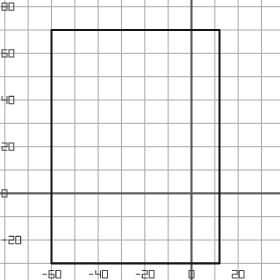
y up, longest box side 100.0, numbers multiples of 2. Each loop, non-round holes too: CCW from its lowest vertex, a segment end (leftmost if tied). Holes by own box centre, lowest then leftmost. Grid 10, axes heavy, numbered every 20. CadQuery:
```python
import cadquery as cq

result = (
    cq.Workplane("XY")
    .moveTo(-60.0, -30.0)
    .lineTo(12.0, -30.0)
    .lineTo(12.0, 70.0)
    .lineTo(-60.0, 70.0)
    .close()
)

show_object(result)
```